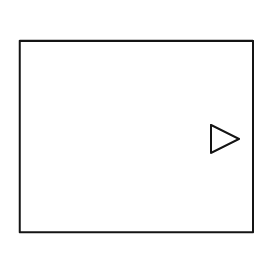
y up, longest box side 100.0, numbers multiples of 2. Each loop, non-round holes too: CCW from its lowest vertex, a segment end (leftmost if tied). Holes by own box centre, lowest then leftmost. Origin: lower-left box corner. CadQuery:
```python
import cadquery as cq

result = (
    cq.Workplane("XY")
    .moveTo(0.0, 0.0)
    .lineTo(100.0, 0.0)
    .lineTo(100.0, 82.0)
    .lineTo(0.0, 82.0)
    .close()
    .moveTo(82.0, 34.0)
    .lineTo(94.0, 40.0)
    .lineTo(82.0, 46.0)
    .close()
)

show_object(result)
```